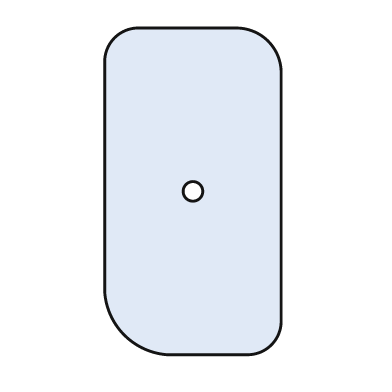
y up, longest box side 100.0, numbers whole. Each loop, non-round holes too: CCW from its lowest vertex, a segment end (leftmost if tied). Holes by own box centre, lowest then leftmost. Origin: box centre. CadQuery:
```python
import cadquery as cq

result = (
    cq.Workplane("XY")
    .moveTo(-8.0, -50.0)
    .lineTo(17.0, -50.0)
    .threePointArc((24.0, -47.0), (27.0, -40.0))
    .lineTo(27.0, 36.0)
    .threePointArc((23.0, 46.0), (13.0, 50.0))
    .lineTo(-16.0, 50.0)
    .threePointArc((-24.0, 47.0), (-27.0, 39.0))
    .lineTo(-27.0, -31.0)
    .threePointArc((-21.0, -44.0), (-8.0, -50.0))
    .close()
    .moveTo(0.0, 0.0)
    .circle(3.0)
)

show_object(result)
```